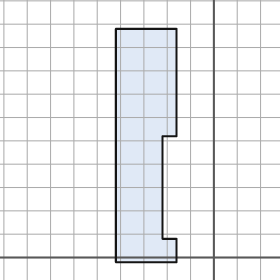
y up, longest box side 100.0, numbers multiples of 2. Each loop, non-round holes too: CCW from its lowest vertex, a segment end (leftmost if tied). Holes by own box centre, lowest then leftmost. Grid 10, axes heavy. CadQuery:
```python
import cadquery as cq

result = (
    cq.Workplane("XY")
    .moveTo(-42.0, -2.0)
    .lineTo(-16.0, -2.0)
    .lineTo(-16.0, 8.0)
    .lineTo(-22.0, 8.0)
    .lineTo(-22.0, 52.0)
    .lineTo(-16.0, 52.0)
    .lineTo(-16.0, 98.0)
    .lineTo(-42.0, 98.0)
    .close()
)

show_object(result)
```